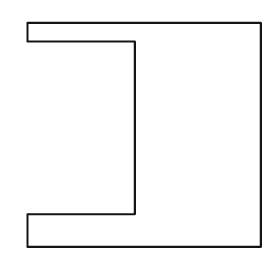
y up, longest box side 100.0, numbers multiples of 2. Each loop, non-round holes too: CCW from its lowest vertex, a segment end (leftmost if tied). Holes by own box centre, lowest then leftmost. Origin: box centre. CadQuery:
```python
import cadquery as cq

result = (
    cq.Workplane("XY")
    .moveTo(-50.0, -48.0)
    .lineTo(50.0, -48.0)
    .lineTo(50.0, 48.0)
    .lineTo(-50.0, 48.0)
    .lineTo(-50.0, 40.0)
    .lineTo(-4.0, 40.0)
    .lineTo(-4.0, -34.0)
    .lineTo(-50.0, -34.0)
    .close()
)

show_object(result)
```